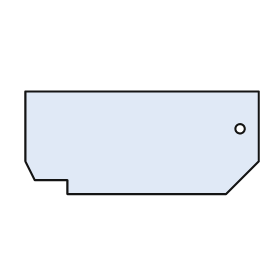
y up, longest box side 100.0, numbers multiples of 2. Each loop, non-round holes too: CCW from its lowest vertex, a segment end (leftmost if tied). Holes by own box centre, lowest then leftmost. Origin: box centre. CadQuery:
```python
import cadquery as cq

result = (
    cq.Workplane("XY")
    .moveTo(-32.0, -22.0)
    .lineTo(36.0, -22.0)
    .lineTo(50.0, -8.0)
    .lineTo(50.0, 22.0)
    .lineTo(-50.0, 22.0)
    .lineTo(-50.0, -8.0)
    .lineTo(-46.0, -16.0)
    .lineTo(-32.0, -16.0)
    .close()
    .moveTo(42.0, 6.0)
    .circle(2.0)
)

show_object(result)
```